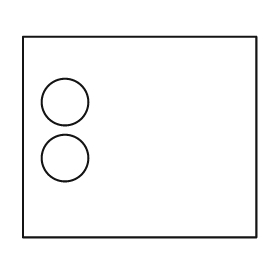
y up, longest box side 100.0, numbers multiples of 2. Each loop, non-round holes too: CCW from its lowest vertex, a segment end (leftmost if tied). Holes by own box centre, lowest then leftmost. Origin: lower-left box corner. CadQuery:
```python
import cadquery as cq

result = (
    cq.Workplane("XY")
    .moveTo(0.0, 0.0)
    .lineTo(100.0, 0.0)
    .lineTo(100.0, 86.0)
    .lineTo(0.0, 86.0)
    .close()
    .moveTo(18.0, 34.0)
    .circle(10.0)
    .moveTo(18.0, 58.0)
    .circle(10.0)
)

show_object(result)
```